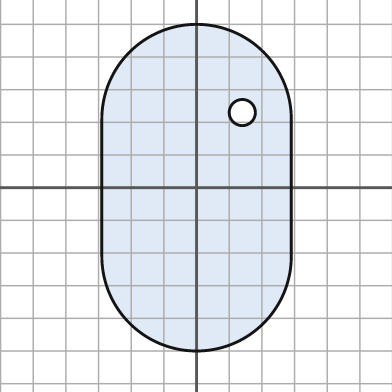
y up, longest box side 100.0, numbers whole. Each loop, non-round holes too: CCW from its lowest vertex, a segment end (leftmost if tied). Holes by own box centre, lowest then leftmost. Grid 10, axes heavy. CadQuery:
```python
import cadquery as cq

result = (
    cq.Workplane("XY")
    .moveTo(-29.0, -21.0)
    .threePointArc((0.0, -50.0), (29.0, -21.0))
    .lineTo(29.0, 21.0)
    .threePointArc((0.0, 50.0), (-29.0, 21.0))
    .close()
    .moveTo(14.0, 23.0)
    .circle(4.0)
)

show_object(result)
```